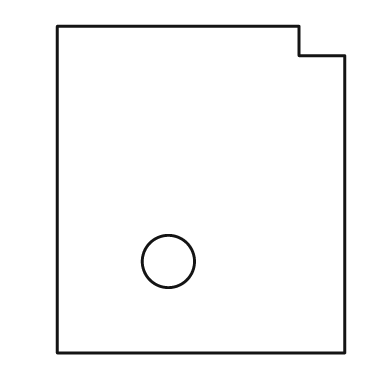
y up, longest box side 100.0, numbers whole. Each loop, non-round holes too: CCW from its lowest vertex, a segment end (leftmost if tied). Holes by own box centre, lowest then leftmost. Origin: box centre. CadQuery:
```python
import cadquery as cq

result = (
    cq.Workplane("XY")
    .moveTo(-44.0, -50.0)
    .lineTo(44.0, -50.0)
    .lineTo(44.0, 41.0)
    .lineTo(30.0, 41.0)
    .lineTo(30.0, 50.0)
    .lineTo(-44.0, 50.0)
    .close()
    .moveTo(-10.0, -22.0)
    .circle(8.0)
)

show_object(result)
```